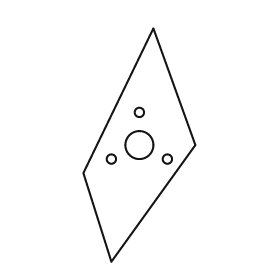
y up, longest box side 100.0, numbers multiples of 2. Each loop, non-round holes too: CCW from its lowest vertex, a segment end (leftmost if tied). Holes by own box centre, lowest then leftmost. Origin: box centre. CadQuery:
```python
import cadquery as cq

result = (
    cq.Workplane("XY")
    .moveTo(-12.0, -50.0)
    .lineTo(24.0, 0.0)
    .lineTo(6.0, 50.0)
    .lineTo(-24.0, -12.0)
    .close()
    .moveTo(-12.0, -6.0)
    .circle(2.0)
    .moveTo(12.0, -6.0)
    .circle(2.0)
    .moveTo(0.0, 0.0)
    .circle(6.0)
    .moveTo(0.0, 14.0)
    .circle(2.0)
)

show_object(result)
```